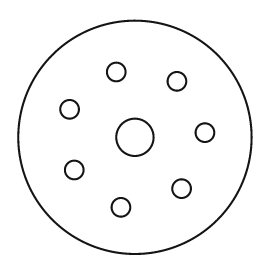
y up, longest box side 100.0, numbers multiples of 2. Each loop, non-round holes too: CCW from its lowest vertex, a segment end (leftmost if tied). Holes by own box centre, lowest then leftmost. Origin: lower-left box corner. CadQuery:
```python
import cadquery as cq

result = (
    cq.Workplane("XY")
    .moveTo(50.0, 50.0)
    .circle(50.0)
    .moveTo(44.0, 20.0)
    .circle(4.0)
    .moveTo(70.0, 28.0)
    .circle(4.0)
    .moveTo(24.0, 36.0)
    .circle(4.0)
    .moveTo(50.0, 50.0)
    .circle(8.0)
    .moveTo(80.0, 52.0)
    .circle(4.0)
    .moveTo(22.0, 62.0)
    .circle(4.0)
    .moveTo(68.0, 74.0)
    .circle(4.0)
    .moveTo(42.0, 78.0)
    .circle(4.0)
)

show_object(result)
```